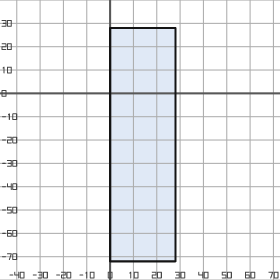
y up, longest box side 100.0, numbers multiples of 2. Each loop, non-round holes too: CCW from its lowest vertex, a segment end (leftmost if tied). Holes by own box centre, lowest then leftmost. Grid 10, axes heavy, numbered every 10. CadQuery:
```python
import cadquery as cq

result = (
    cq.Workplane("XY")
    .moveTo(0.0, -72.0)
    .lineTo(28.0, -72.0)
    .lineTo(28.0, 28.0)
    .lineTo(0.0, 28.0)
    .close()
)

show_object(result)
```